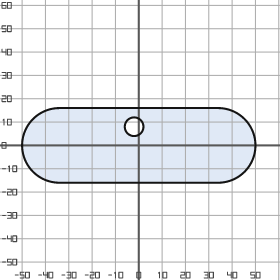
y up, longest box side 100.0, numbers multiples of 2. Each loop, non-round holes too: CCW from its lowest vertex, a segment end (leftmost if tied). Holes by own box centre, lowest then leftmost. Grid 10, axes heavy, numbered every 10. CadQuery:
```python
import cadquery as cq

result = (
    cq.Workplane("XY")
    .moveTo(-34.0, -16.0)
    .lineTo(34.0, -16.0)
    .threePointArc((50.0, 0.0), (34.0, 16.0))
    .lineTo(-34.0, 16.0)
    .threePointArc((-50.0, 0.0), (-34.0, -16.0))
    .close()
    .moveTo(-2.0, 8.0)
    .circle(4.0)
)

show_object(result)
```